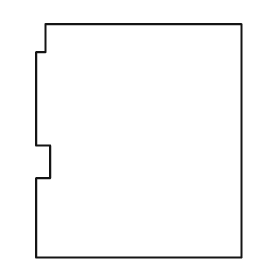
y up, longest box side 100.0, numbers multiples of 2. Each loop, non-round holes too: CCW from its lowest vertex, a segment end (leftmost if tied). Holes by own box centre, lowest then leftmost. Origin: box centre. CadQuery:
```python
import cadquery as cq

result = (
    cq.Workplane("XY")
    .moveTo(-44.0, -50.0)
    .lineTo(44.0, -50.0)
    .lineTo(44.0, 50.0)
    .lineTo(-40.0, 50.0)
    .lineTo(-40.0, 38.0)
    .lineTo(-44.0, 38.0)
    .lineTo(-44.0, -2.0)
    .lineTo(-38.0, -2.0)
    .lineTo(-38.0, -16.0)
    .lineTo(-44.0, -16.0)
    .close()
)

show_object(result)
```